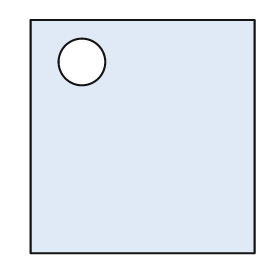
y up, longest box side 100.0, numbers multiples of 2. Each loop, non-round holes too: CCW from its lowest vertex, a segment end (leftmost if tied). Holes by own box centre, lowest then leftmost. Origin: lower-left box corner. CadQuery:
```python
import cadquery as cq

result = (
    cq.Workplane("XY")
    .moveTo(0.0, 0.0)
    .lineTo(96.0, 0.0)
    .lineTo(96.0, 100.0)
    .lineTo(0.0, 100.0)
    .close()
    .moveTo(22.0, 82.0)
    .circle(10.0)
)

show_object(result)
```